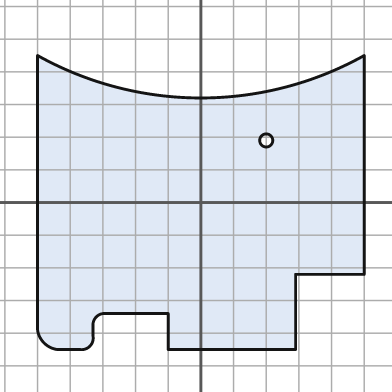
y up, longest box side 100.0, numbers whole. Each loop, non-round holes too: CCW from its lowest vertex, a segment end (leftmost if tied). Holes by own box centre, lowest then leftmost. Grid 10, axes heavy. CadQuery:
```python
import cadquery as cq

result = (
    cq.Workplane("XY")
    .moveTo(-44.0, -45.0)
    .lineTo(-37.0, -45.0)
    .threePointArc((-34.0, -44.0), (-33.0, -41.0))
    .lineTo(-33.0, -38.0)
    .threePointArc((-32.0, -35.0), (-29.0, -34.0))
    .lineTo(-10.0, -34.0)
    .lineTo(-10.0, -45.0)
    .lineTo(29.0, -45.0)
    .lineTo(29.0, -22.0)
    .lineTo(50.0, -22.0)
    .lineTo(50.0, 45.0)
    .threePointArc((0.0, 32.0), (-50.0, 45.0))
    .lineTo(-50.0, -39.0)
    .threePointArc((-48.0, -43.0), (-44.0, -45.0))
    .close()
    .moveTo(20.0, 19.0)
    .circle(2.0)
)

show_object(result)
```